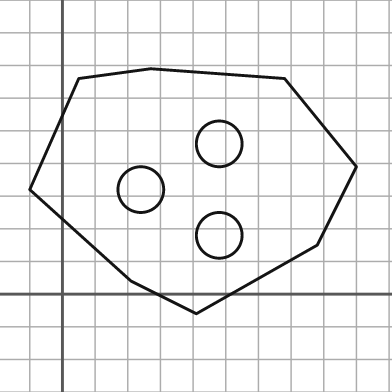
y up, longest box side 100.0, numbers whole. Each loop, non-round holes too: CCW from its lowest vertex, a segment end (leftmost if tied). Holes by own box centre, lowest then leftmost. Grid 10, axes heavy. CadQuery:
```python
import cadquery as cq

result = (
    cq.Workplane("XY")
    .moveTo(41.0, -6.0)
    .lineTo(78.0, 15.0)
    .lineTo(90.0, 39.0)
    .lineTo(68.0, 66.0)
    .lineTo(27.0, 69.0)
    .lineTo(5.0, 66.0)
    .lineTo(-10.0, 32.0)
    .lineTo(21.0, 4.0)
    .close()
    .moveTo(48.0, 18.0)
    .circle(7.0)
    .moveTo(24.0, 32.0)
    .circle(7.0)
    .moveTo(48.0, 46.0)
    .circle(7.0)
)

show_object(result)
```